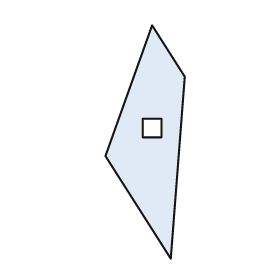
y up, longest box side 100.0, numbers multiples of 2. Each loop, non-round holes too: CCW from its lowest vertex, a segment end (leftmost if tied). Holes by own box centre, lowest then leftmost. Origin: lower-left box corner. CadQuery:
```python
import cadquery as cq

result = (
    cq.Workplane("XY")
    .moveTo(28.0, 0.0)
    .lineTo(34.0, 78.0)
    .lineTo(20.0, 100.0)
    .lineTo(0.0, 44.0)
    .close()
    .moveTo(16.0, 52.0)
    .lineTo(24.0, 52.0)
    .lineTo(24.0, 60.0)
    .lineTo(16.0, 60.0)
    .close()
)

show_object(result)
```